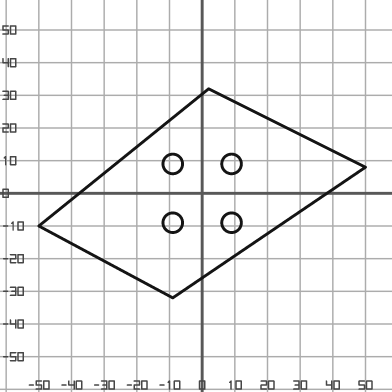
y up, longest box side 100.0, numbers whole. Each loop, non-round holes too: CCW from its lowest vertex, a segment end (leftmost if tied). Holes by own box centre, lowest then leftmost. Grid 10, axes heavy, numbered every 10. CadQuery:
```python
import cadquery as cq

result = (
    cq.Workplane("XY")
    .moveTo(-9.0, -32.0)
    .lineTo(50.0, 8.0)
    .lineTo(2.0, 32.0)
    .lineTo(-50.0, -10.0)
    .close()
    .moveTo(-9.0, -9.0)
    .circle(3.0)
    .moveTo(9.0, -9.0)
    .circle(3.0)
    .moveTo(-9.0, 9.0)
    .circle(3.0)
    .moveTo(9.0, 9.0)
    .circle(3.0)
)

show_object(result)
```